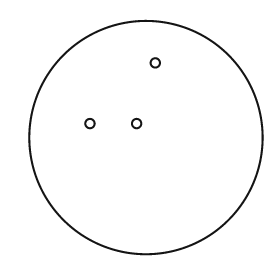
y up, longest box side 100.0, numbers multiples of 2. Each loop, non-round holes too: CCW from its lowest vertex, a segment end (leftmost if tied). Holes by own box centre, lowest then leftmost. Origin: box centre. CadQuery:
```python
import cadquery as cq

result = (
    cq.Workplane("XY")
    .moveTo(0.0, 0.0)
    .circle(50.0)
    .moveTo(-24.0, 6.0)
    .circle(2.0)
    .moveTo(-4.0, 6.0)
    .circle(2.0)
    .moveTo(4.0, 32.0)
    .circle(2.0)
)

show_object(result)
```